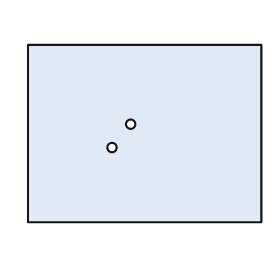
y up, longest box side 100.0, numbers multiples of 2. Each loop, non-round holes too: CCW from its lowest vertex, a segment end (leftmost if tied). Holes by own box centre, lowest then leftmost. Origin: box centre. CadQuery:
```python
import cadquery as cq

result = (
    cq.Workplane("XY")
    .moveTo(-50.0, -38.0)
    .lineTo(50.0, -38.0)
    .lineTo(50.0, 38.0)
    .lineTo(-50.0, 38.0)
    .close()
    .moveTo(-14.0, -6.0)
    .circle(2.0)
    .moveTo(-6.0, 4.0)
    .circle(2.0)
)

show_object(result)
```